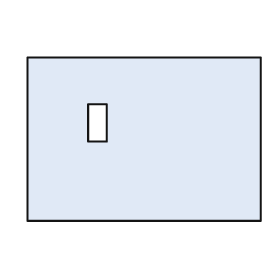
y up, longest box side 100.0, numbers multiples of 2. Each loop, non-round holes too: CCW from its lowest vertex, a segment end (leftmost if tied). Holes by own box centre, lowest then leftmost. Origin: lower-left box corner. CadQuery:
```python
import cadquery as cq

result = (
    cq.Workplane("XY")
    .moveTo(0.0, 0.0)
    .lineTo(100.0, 0.0)
    .lineTo(100.0, 70.0)
    .lineTo(0.0, 70.0)
    .close()
    .moveTo(26.0, 34.0)
    .lineTo(34.0, 34.0)
    .lineTo(34.0, 50.0)
    .lineTo(26.0, 50.0)
    .close()
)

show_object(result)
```